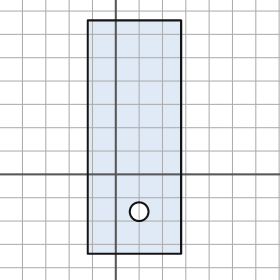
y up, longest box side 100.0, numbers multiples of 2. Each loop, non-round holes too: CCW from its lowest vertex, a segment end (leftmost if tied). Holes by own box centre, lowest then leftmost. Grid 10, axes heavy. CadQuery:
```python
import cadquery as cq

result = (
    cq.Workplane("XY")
    .moveTo(-12.0, -34.0)
    .lineTo(28.0, -34.0)
    .lineTo(28.0, 66.0)
    .lineTo(-12.0, 66.0)
    .close()
    .moveTo(10.0, -16.0)
    .circle(4.0)
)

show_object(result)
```